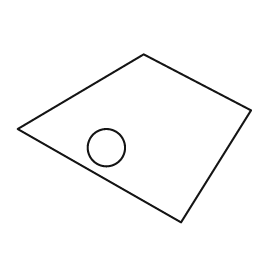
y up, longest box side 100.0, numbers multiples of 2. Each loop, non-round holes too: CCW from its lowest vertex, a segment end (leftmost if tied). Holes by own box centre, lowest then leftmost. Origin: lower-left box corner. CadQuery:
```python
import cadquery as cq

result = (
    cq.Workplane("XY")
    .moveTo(70.0, 0.0)
    .lineTo(100.0, 48.0)
    .lineTo(54.0, 72.0)
    .lineTo(0.0, 40.0)
    .close()
    .moveTo(38.0, 32.0)
    .circle(8.0)
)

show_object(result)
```